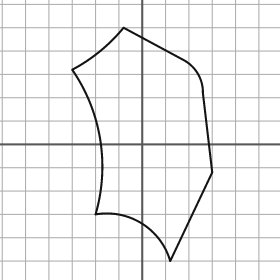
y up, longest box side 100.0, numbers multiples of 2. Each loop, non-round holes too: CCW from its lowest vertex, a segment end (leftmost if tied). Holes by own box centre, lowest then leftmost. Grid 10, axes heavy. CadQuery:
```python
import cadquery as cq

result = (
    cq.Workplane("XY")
    .moveTo(12.0, -50.0)
    .lineTo(30.0, -12.0)
    .lineTo(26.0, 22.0)
    .threePointArc((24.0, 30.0), (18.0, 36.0))
    .lineTo(-8.0, 50.0)
    .threePointArc((-18.0, 40.0), (-30.0, 32.0))
    .threePointArc((-18.0, 2.0), (-20.0, -30.0))
    .threePointArc((0.0, -34.0), (12.0, -50.0))
    .close()
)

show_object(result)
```